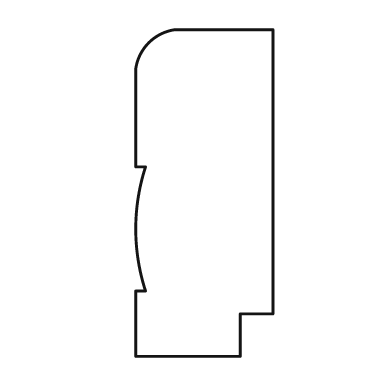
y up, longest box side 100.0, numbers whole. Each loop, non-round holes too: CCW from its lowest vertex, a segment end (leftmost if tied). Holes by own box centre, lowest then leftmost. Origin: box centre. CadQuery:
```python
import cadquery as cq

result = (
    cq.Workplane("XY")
    .moveTo(-21.0, -50.0)
    .lineTo(11.0, -50.0)
    .lineTo(11.0, -37.0)
    .lineTo(21.0, -37.0)
    .lineTo(21.0, 50.0)
    .lineTo(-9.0, 50.0)
    .threePointArc((-17.0, 46.0), (-21.0, 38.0))
    .lineTo(-21.0, 8.0)
    .lineTo(-18.0, 8.0)
    .threePointArc((-21.0, -11.0), (-18.0, -30.0))
    .lineTo(-21.0, -30.0)
    .close()
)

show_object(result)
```